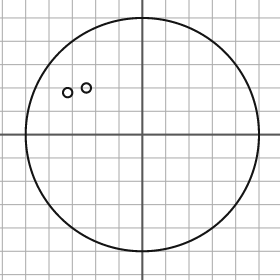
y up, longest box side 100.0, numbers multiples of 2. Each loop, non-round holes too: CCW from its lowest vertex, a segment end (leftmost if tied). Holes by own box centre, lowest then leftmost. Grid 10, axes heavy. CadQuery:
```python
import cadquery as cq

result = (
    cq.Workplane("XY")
    .moveTo(0.0, 0.0)
    .circle(50.0)
    .moveTo(-32.0, 18.0)
    .circle(2.0)
    .moveTo(-24.0, 20.0)
    .circle(2.0)
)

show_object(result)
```